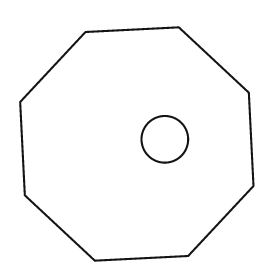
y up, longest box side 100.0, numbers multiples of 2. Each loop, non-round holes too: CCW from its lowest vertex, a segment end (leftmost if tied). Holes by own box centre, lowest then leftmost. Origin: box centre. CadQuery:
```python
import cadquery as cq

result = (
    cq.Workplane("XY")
    .moveTo(-18.0, -50.0)
    .lineTo(22.0, -48.0)
    .lineTo(50.0, -18.0)
    .lineTo(48.0, 22.0)
    .lineTo(18.0, 50.0)
    .lineTo(-22.0, 48.0)
    .lineTo(-50.0, 18.0)
    .lineTo(-48.0, -22.0)
    .close()
    .moveTo(12.0, 2.0)
    .circle(10.0)
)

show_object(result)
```